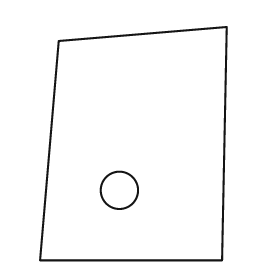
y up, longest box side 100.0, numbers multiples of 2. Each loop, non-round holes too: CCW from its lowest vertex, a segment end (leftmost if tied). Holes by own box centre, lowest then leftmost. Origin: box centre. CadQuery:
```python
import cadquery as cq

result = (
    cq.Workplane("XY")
    .moveTo(-40.0, -50.0)
    .lineTo(38.0, -50.0)
    .lineTo(40.0, 50.0)
    .lineTo(-32.0, 44.0)
    .close()
    .moveTo(-6.0, -20.0)
    .circle(8.0)
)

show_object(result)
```